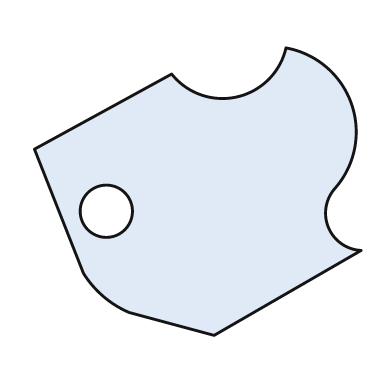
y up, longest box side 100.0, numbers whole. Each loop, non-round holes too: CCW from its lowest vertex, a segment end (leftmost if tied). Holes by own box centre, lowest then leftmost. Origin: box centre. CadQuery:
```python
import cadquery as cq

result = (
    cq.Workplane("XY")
    .moveTo(5.0, -44.0)
    .lineTo(50.0, -18.0)
    .threePointArc((40.0, -11.0), (42.0, 1.0))
    .threePointArc((47.0, 27.0), (27.0, 44.0))
    .threePointArc((12.0, 29.0), (-8.0, 36.0))
    .lineTo(-50.0, 13.0)
    .lineTo(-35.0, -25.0)
    .threePointArc((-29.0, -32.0), (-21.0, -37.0))
    .close()
    .moveTo(-28.0, -6.0)
    .circle(8.0)
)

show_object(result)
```